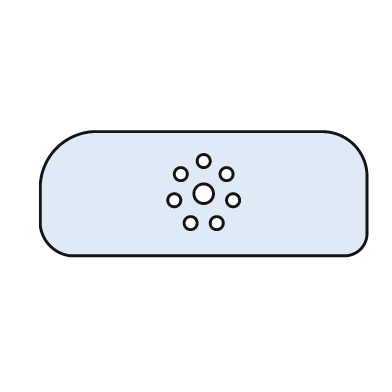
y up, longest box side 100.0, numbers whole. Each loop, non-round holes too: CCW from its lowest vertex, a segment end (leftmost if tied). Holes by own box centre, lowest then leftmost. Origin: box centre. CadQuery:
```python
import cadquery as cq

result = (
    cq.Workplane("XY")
    .moveTo(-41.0, -19.0)
    .lineTo(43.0, -19.0)
    .threePointArc((48.0, -17.0), (50.0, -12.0))
    .lineTo(50.0, 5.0)
    .threePointArc((46.0, 15.0), (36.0, 19.0))
    .lineTo(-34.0, 19.0)
    .threePointArc((-45.0, 14.0), (-50.0, 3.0))
    .lineTo(-50.0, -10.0)
    .threePointArc((-47.0, -16.0), (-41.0, -19.0))
    .close()
    .moveTo(-4.0, -9.0)
    .circle(2.0)
    .moveTo(4.0, -9.0)
    .circle(2.0)
    .moveTo(-9.0, -2.0)
    .circle(2.0)
    .moveTo(9.0, -2.0)
    .circle(2.0)
    .moveTo(0.0, 0.0)
    .circle(3.0)
    .moveTo(-7.0, 6.0)
    .circle(2.0)
    .moveTo(7.0, 6.0)
    .circle(2.0)
    .moveTo(0.0, 10.0)
    .circle(2.0)
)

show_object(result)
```